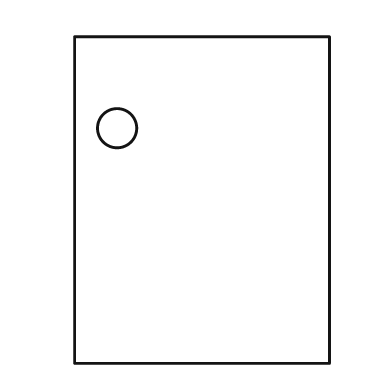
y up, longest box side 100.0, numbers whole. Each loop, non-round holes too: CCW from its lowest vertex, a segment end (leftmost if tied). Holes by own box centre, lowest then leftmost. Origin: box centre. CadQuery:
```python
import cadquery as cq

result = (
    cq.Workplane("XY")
    .moveTo(-39.0, -50.0)
    .lineTo(39.0, -50.0)
    .lineTo(39.0, 50.0)
    .lineTo(-39.0, 50.0)
    .close()
    .moveTo(-26.0, 22.0)
    .circle(6.0)
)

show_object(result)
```